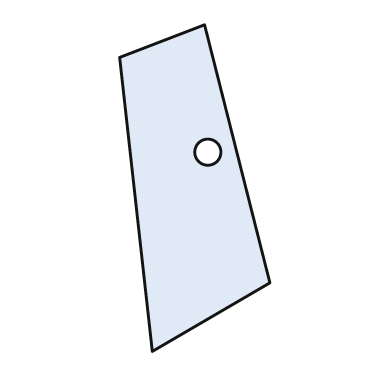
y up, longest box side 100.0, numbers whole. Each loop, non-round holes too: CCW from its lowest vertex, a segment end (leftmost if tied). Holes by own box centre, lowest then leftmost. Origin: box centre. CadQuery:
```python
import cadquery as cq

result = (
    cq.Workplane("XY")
    .moveTo(-13.0, -50.0)
    .lineTo(23.0, -29.0)
    .lineTo(3.0, 50.0)
    .lineTo(-23.0, 40.0)
    .close()
    .moveTo(4.0, 11.0)
    .circle(4.0)
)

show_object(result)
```